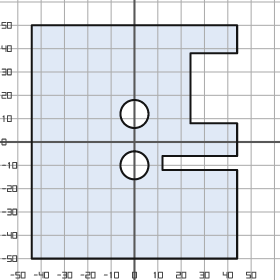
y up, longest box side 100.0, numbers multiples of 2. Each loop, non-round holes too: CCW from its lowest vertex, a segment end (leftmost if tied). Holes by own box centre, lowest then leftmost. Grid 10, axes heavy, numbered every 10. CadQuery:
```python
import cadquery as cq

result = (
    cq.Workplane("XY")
    .moveTo(-44.0, -50.0)
    .lineTo(44.0, -50.0)
    .lineTo(44.0, -12.0)
    .lineTo(12.0, -12.0)
    .lineTo(12.0, -6.0)
    .lineTo(44.0, -6.0)
    .lineTo(44.0, 8.0)
    .lineTo(24.0, 8.0)
    .lineTo(24.0, 38.0)
    .lineTo(44.0, 38.0)
    .lineTo(44.0, 50.0)
    .lineTo(-44.0, 50.0)
    .close()
    .moveTo(0.0, -10.0)
    .circle(6.0)
    .moveTo(0.0, 12.0)
    .circle(6.0)
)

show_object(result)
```